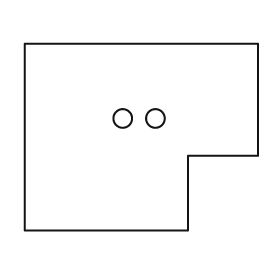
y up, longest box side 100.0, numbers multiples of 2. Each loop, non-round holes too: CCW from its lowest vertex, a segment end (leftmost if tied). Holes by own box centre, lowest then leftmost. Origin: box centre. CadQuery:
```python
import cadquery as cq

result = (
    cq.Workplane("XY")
    .moveTo(-50.0, -40.0)
    .lineTo(20.0, -40.0)
    .lineTo(20.0, -8.0)
    .lineTo(50.0, -8.0)
    .lineTo(50.0, 40.0)
    .lineTo(-50.0, 40.0)
    .close()
    .moveTo(-8.0, 8.0)
    .circle(4.0)
    .moveTo(6.0, 8.0)
    .circle(4.0)
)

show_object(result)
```